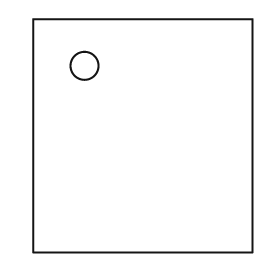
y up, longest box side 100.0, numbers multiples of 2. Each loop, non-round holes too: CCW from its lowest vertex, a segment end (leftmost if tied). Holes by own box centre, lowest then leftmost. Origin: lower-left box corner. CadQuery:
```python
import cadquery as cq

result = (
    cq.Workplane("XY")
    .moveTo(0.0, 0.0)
    .lineTo(94.0, 0.0)
    .lineTo(94.0, 100.0)
    .lineTo(0.0, 100.0)
    .close()
    .moveTo(22.0, 80.0)
    .circle(6.0)
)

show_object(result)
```